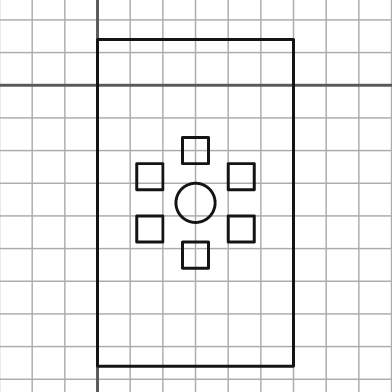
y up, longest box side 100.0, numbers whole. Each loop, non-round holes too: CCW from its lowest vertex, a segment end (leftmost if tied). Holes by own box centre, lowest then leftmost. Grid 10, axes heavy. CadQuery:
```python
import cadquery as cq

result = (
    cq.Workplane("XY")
    .moveTo(0.0, -86.0)
    .lineTo(60.0, -86.0)
    .lineTo(60.0, 14.0)
    .lineTo(0.0, 14.0)
    .close()
    .moveTo(26.0, -56.0)
    .lineTo(34.0, -56.0)
    .lineTo(34.0, -48.0)
    .lineTo(26.0, -48.0)
    .close()
    .moveTo(12.0, -48.0)
    .lineTo(20.0, -48.0)
    .lineTo(20.0, -40.0)
    .lineTo(12.0, -40.0)
    .close()
    .moveTo(40.0, -48.0)
    .lineTo(48.0, -48.0)
    .lineTo(48.0, -40.0)
    .lineTo(40.0, -40.0)
    .close()
    .moveTo(30.0, -36.0)
    .circle(6.0)
    .moveTo(12.0, -32.0)
    .lineTo(20.0, -32.0)
    .lineTo(20.0, -24.0)
    .lineTo(12.0, -24.0)
    .close()
    .moveTo(40.0, -32.0)
    .lineTo(48.0, -32.0)
    .lineTo(48.0, -24.0)
    .lineTo(40.0, -24.0)
    .close()
    .moveTo(26.0, -24.0)
    .lineTo(34.0, -24.0)
    .lineTo(34.0, -16.0)
    .lineTo(26.0, -16.0)
    .close()
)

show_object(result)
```